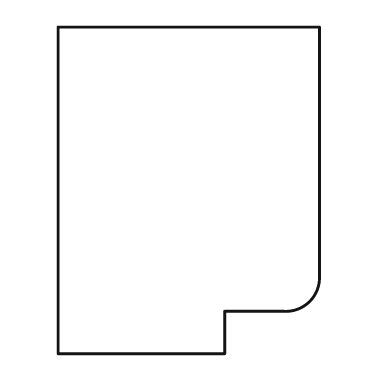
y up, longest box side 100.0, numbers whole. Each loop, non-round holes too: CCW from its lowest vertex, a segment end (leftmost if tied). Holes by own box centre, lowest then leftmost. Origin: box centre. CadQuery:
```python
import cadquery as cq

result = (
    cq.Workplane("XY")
    .moveTo(-40.0, -50.0)
    .lineTo(11.0, -50.0)
    .lineTo(11.0, -37.0)
    .lineTo(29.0, -37.0)
    .threePointArc((37.0, -34.0), (40.0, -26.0))
    .lineTo(40.0, 50.0)
    .lineTo(-40.0, 50.0)
    .close()
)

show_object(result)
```